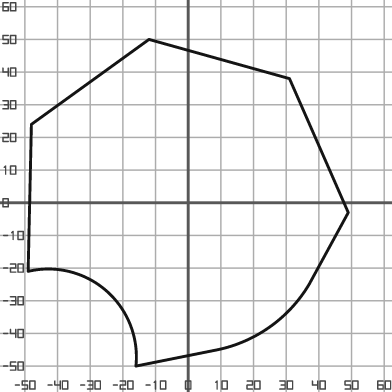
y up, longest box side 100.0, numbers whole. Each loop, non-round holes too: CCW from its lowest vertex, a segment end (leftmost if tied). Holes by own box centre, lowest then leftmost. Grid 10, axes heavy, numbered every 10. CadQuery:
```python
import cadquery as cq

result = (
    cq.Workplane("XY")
    .moveTo(-16.0, -50.0)
    .lineTo(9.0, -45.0)
    .threePointArc((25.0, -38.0), (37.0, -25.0))
    .lineTo(49.0, -3.0)
    .lineTo(31.0, 38.0)
    .lineTo(-12.0, 50.0)
    .lineTo(-48.0, 24.0)
    .lineTo(-49.0, -21.0)
    .threePointArc((-25.0, -27.0), (-16.0, -50.0))
    .close()
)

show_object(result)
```